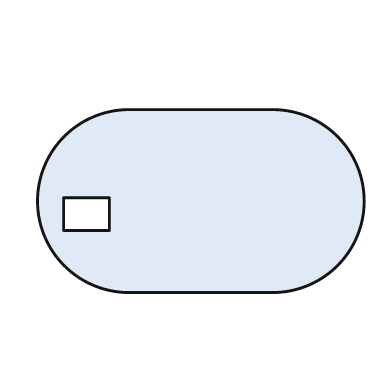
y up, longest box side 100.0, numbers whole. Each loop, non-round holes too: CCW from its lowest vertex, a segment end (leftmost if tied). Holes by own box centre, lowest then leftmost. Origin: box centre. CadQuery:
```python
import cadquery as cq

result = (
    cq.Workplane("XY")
    .moveTo(-22.0, -28.0)
    .lineTo(22.0, -28.0)
    .threePointArc((50.0, 0.0), (22.0, 28.0))
    .lineTo(-22.0, 28.0)
    .threePointArc((-50.0, 0.0), (-22.0, -28.0))
    .close()
    .moveTo(-42.0, -9.0)
    .lineTo(-28.0, -9.0)
    .lineTo(-28.0, 1.0)
    .lineTo(-42.0, 1.0)
    .close()
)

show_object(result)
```